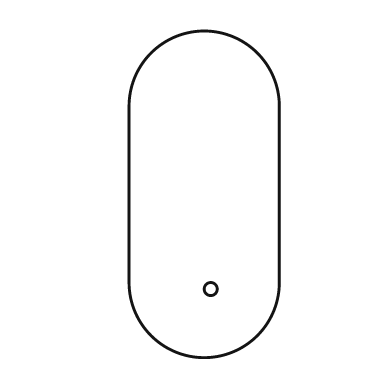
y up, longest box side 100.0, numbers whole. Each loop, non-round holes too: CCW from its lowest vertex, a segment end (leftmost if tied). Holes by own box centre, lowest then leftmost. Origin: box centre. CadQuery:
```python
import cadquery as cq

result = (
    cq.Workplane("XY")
    .moveTo(-23.0, -27.0)
    .threePointArc((0.0, -50.0), (23.0, -27.0))
    .lineTo(23.0, 27.0)
    .threePointArc((0.0, 50.0), (-23.0, 27.0))
    .close()
    .moveTo(2.0, -29.0)
    .circle(2.0)
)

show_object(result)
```